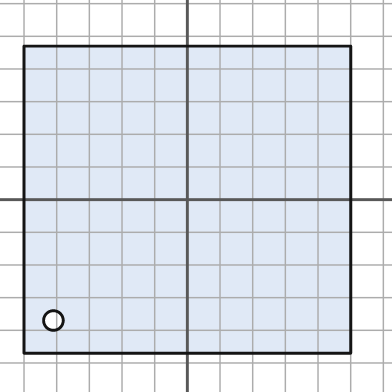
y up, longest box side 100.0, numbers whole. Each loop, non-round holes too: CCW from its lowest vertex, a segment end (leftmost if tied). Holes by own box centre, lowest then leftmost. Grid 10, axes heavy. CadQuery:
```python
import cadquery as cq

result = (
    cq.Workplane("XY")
    .moveTo(-50.0, -47.0)
    .lineTo(50.0, -47.0)
    .lineTo(50.0, 47.0)
    .lineTo(-50.0, 47.0)
    .close()
    .moveTo(-41.0, -37.0)
    .circle(3.0)
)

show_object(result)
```